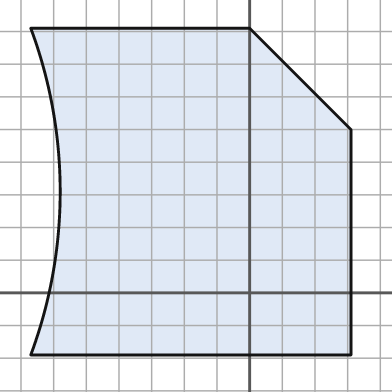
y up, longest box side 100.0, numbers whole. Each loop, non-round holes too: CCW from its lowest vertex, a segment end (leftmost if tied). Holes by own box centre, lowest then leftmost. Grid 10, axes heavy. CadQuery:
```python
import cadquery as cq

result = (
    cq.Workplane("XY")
    .moveTo(-67.0, -19.0)
    .lineTo(31.0, -19.0)
    .lineTo(31.0, 50.0)
    .lineTo(0.0, 81.0)
    .lineTo(-67.0, 81.0)
    .threePointArc((-58.0, 31.0), (-67.0, -19.0))
    .close()
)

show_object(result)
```